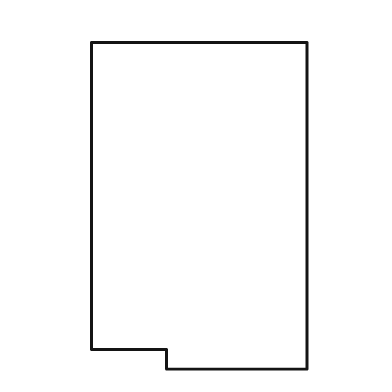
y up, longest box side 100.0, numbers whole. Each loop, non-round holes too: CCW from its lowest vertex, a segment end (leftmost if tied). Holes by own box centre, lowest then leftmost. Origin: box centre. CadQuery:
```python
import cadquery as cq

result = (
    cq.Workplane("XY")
    .moveTo(-10.0, -50.0)
    .lineTo(33.0, -50.0)
    .lineTo(33.0, 50.0)
    .lineTo(-33.0, 50.0)
    .lineTo(-33.0, -44.0)
    .lineTo(-10.0, -44.0)
    .close()
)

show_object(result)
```